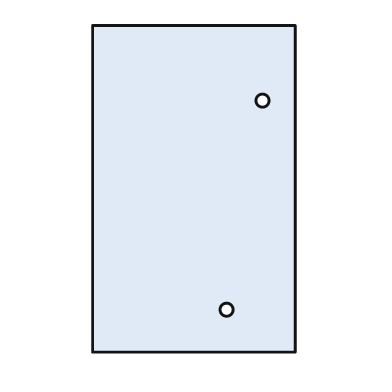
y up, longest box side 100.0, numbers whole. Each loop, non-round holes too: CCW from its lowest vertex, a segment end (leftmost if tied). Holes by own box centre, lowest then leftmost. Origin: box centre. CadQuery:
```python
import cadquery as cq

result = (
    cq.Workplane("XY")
    .moveTo(-31.0, -50.0)
    .lineTo(31.0, -50.0)
    .lineTo(31.0, 50.0)
    .lineTo(-31.0, 50.0)
    .close()
    .moveTo(10.0, -37.0)
    .circle(2.0)
    .moveTo(21.0, 27.0)
    .circle(2.0)
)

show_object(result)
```